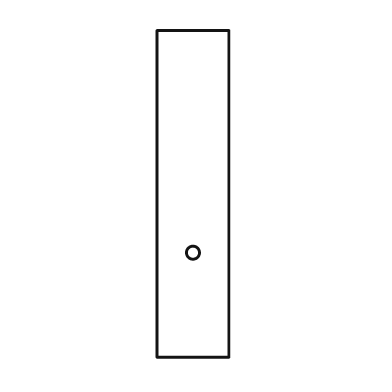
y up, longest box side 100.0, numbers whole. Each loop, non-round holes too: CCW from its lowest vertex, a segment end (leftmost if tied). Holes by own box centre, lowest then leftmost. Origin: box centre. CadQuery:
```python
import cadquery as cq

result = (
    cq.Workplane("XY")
    .moveTo(-11.0, -50.0)
    .lineTo(11.0, -50.0)
    .lineTo(11.0, 50.0)
    .lineTo(-11.0, 50.0)
    .close()
    .moveTo(0.0, -18.0)
    .circle(2.0)
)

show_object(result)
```